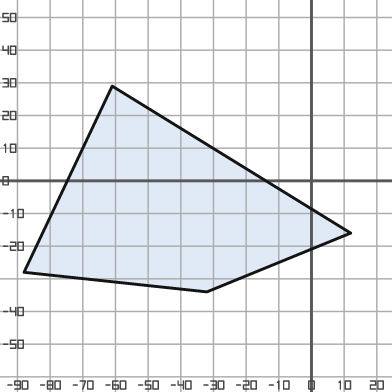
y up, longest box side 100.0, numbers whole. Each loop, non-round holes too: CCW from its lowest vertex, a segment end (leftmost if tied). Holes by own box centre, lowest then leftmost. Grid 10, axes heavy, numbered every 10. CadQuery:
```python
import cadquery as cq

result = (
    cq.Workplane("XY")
    .moveTo(-32.0, -34.0)
    .lineTo(12.0, -16.0)
    .lineTo(-61.0, 29.0)
    .lineTo(-88.0, -28.0)
    .close()
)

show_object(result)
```